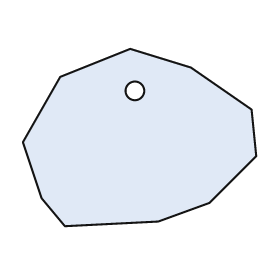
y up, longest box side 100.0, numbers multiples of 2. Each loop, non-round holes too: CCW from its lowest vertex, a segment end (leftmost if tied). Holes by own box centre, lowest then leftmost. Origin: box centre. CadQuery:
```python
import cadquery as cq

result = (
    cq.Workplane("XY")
    .moveTo(-32.0, -38.0)
    .lineTo(8.0, -36.0)
    .lineTo(30.0, -28.0)
    .lineTo(50.0, -8.0)
    .lineTo(48.0, 12.0)
    .lineTo(22.0, 30.0)
    .lineTo(-4.0, 38.0)
    .lineTo(-34.0, 26.0)
    .lineTo(-50.0, -2.0)
    .lineTo(-42.0, -26.0)
    .close()
    .moveTo(-2.0, 20.0)
    .circle(4.0)
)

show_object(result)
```